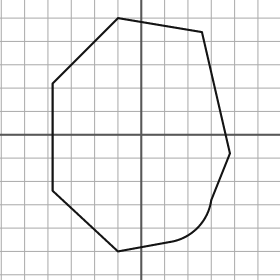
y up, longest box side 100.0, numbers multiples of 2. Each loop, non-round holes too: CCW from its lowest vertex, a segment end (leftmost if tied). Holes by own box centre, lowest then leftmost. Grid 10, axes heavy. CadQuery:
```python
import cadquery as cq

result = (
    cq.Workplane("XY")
    .moveTo(-10.0, -50.0)
    .lineTo(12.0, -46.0)
    .threePointArc((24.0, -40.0), (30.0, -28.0))
    .lineTo(38.0, -8.0)
    .lineTo(26.0, 44.0)
    .lineTo(-10.0, 50.0)
    .lineTo(-38.0, 22.0)
    .lineTo(-38.0, -24.0)
    .close()
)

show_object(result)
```